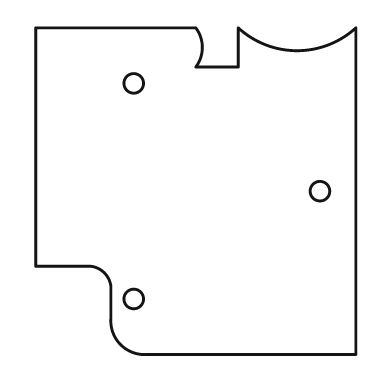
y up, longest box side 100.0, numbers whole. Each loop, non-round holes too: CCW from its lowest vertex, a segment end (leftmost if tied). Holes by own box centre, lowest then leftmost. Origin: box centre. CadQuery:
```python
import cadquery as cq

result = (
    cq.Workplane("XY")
    .moveTo(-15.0, -50.0)
    .lineTo(49.0, -50.0)
    .lineTo(49.0, 50.0)
    .threePointArc((31.0, 43.0), (13.0, 50.0))
    .lineTo(13.0, 38.0)
    .lineTo(0.0, 38.0)
    .threePointArc((2.0, 44.0), (0.0, 50.0))
    .lineTo(-49.0, 50.0)
    .lineTo(-49.0, -23.0)
    .lineTo(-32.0, -23.0)
    .threePointArc((-28.0, -25.0), (-26.0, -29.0))
    .lineTo(-26.0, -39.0)
    .threePointArc((-23.0, -47.0), (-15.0, -50.0))
    .close()
    .moveTo(-19.0, -33.0)
    .circle(3.0)
    .moveTo(38.0, 0.0)
    .circle(3.0)
    .moveTo(-19.0, 33.0)
    .circle(3.0)
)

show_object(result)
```